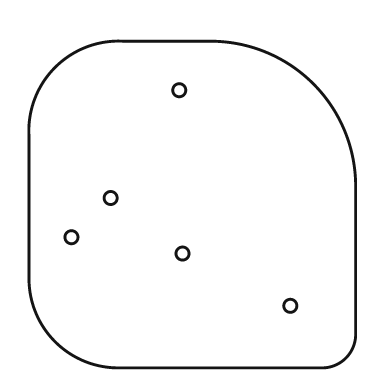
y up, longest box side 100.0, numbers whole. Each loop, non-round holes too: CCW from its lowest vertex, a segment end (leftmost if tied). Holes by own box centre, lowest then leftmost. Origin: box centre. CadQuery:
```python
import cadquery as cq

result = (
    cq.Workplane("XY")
    .moveTo(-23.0, -50.0)
    .lineTo(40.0, -50.0)
    .threePointArc((47.0, -47.0), (50.0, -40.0))
    .lineTo(50.0, 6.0)
    .threePointArc((37.0, 37.0), (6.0, 50.0))
    .lineTo(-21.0, 50.0)
    .threePointArc((-42.0, 42.0), (-50.0, 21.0))
    .lineTo(-50.0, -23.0)
    .threePointArc((-42.0, -42.0), (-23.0, -50.0))
    .close()
    .moveTo(30.0, -31.0)
    .circle(2.0)
    .moveTo(-3.0, -15.0)
    .circle(2.0)
    .moveTo(-37.0, -10.0)
    .circle(2.0)
    .moveTo(-25.0, 2.0)
    .circle(2.0)
    .moveTo(-4.0, 35.0)
    .circle(2.0)
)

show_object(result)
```